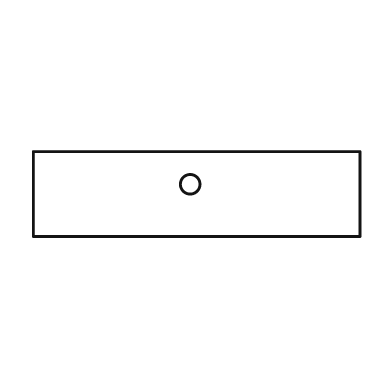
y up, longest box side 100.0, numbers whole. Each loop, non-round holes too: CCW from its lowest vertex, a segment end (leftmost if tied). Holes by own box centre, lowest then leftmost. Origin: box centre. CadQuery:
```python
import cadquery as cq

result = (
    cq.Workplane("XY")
    .moveTo(-50.0, -13.0)
    .lineTo(50.0, -13.0)
    .lineTo(50.0, 13.0)
    .lineTo(-50.0, 13.0)
    .close()
    .moveTo(-2.0, 3.0)
    .circle(3.0)
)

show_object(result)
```